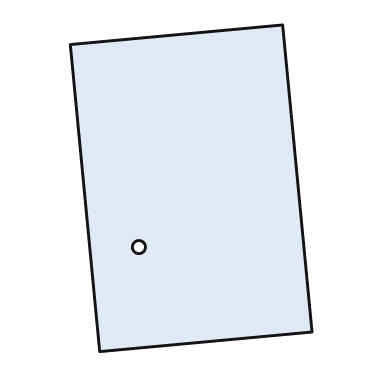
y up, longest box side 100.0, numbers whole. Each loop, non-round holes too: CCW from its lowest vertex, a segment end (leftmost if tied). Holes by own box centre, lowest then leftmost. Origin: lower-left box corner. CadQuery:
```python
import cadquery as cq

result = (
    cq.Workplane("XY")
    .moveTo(9.0, 0.0)
    .lineTo(74.0, 6.0)
    .lineTo(65.0, 100.0)
    .lineTo(0.0, 94.0)
    .close()
    .moveTo(21.0, 32.0)
    .circle(2.0)
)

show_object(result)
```